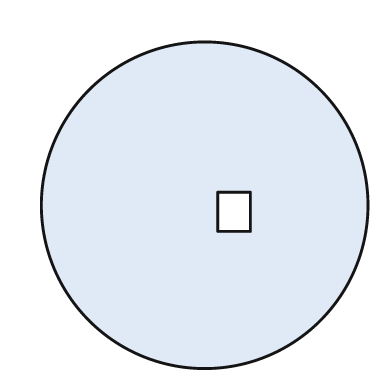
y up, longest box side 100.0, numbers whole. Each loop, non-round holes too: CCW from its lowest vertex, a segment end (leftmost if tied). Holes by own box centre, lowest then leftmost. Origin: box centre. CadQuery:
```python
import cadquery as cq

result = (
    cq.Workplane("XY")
    .moveTo(0.0, 0.0)
    .circle(50.0)
    .moveTo(4.0, -8.0)
    .lineTo(14.0, -8.0)
    .lineTo(14.0, 4.0)
    .lineTo(4.0, 4.0)
    .close()
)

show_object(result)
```